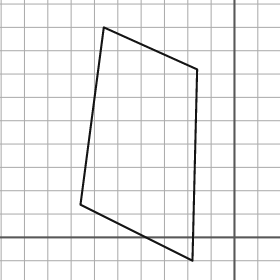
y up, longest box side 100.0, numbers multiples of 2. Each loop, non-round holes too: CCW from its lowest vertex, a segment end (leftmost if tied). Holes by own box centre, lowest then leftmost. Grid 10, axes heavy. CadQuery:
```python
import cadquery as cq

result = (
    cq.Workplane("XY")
    .moveTo(-18.0, -10.0)
    .lineTo(-16.0, 72.0)
    .lineTo(-56.0, 90.0)
    .lineTo(-66.0, 14.0)
    .close()
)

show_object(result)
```